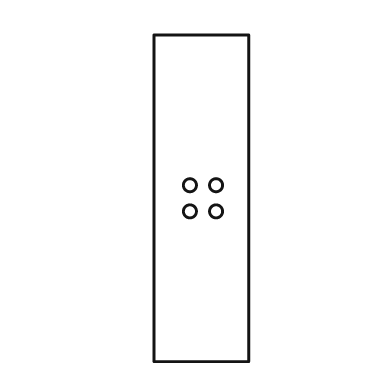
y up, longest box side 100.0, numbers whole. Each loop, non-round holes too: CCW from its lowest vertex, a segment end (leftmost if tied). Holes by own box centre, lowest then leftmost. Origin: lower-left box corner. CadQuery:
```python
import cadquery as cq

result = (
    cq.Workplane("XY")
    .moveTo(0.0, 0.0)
    .lineTo(29.0, 0.0)
    .lineTo(29.0, 100.0)
    .lineTo(0.0, 100.0)
    .close()
    .moveTo(11.0, 46.0)
    .circle(2.0)
    .moveTo(19.0, 46.0)
    .circle(2.0)
    .moveTo(11.0, 54.0)
    .circle(2.0)
    .moveTo(19.0, 54.0)
    .circle(2.0)
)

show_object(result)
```